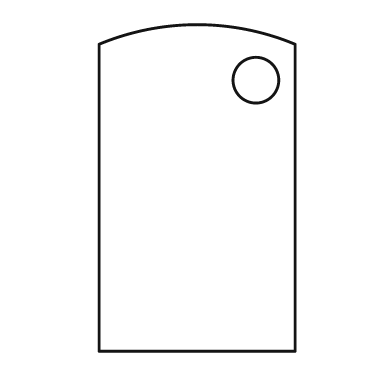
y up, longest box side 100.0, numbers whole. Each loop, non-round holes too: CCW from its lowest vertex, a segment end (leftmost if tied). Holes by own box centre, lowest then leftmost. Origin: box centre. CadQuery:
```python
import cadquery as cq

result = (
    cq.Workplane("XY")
    .moveTo(-30.0, -50.0)
    .lineTo(30.0, -50.0)
    .lineTo(30.0, 44.0)
    .threePointArc((0.0, 50.0), (-30.0, 44.0))
    .close()
    .moveTo(18.0, 33.0)
    .circle(7.0)
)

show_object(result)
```